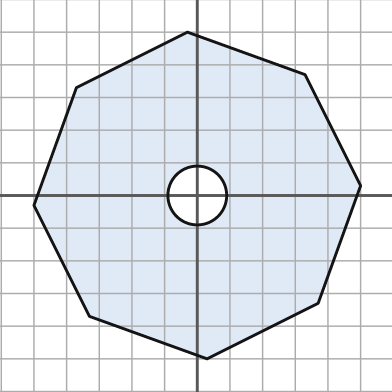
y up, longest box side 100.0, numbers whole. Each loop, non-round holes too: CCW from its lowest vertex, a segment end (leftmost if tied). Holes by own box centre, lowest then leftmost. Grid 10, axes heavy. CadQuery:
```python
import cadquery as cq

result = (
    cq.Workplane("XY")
    .moveTo(3.0, -50.0)
    .lineTo(37.0, -33.0)
    .lineTo(50.0, 3.0)
    .lineTo(33.0, 37.0)
    .lineTo(-3.0, 50.0)
    .lineTo(-37.0, 33.0)
    .lineTo(-50.0, -3.0)
    .lineTo(-33.0, -37.0)
    .close()
    .moveTo(0.0, 0.0)
    .circle(9.0)
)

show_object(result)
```